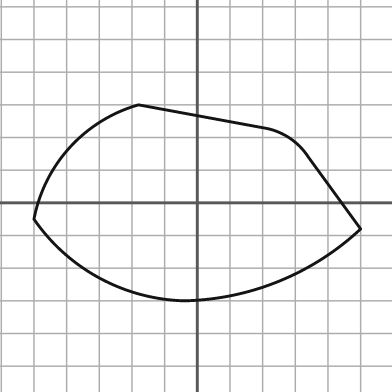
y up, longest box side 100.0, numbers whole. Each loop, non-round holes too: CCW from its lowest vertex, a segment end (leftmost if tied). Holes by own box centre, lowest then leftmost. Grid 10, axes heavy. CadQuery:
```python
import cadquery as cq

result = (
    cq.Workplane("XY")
    .moveTo(-4.0, -30.0)
    .threePointArc((25.0, -24.0), (50.0, -8.0))
    .lineTo(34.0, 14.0)
    .threePointArc((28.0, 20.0), (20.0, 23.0))
    .lineTo(-18.0, 30.0)
    .threePointArc((-39.0, 17.0), (-50.0, -5.0))
    .threePointArc((-30.0, -23.0), (-4.0, -30.0))
    .close()
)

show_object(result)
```